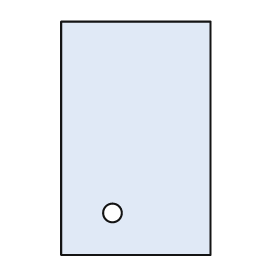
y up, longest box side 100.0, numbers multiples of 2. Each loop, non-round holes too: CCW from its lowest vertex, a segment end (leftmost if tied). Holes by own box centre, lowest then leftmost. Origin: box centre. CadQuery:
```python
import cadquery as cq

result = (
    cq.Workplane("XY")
    .moveTo(-32.0, -50.0)
    .lineTo(32.0, -50.0)
    .lineTo(32.0, 50.0)
    .lineTo(-32.0, 50.0)
    .close()
    .moveTo(-10.0, -32.0)
    .circle(4.0)
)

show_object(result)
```